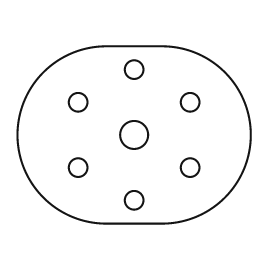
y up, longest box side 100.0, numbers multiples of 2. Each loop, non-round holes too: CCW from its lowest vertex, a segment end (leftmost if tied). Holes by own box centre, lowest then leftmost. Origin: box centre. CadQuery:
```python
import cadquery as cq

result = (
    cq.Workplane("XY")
    .moveTo(-12.0, -38.0)
    .lineTo(12.0, -38.0)
    .threePointArc((50.0, 0.0), (12.0, 38.0))
    .lineTo(-12.0, 38.0)
    .threePointArc((-50.0, 0.0), (-12.0, -38.0))
    .close()
    .moveTo(0.0, -28.0)
    .circle(4.0)
    .moveTo(-24.0, -14.0)
    .circle(4.0)
    .moveTo(24.0, -14.0)
    .circle(4.0)
    .moveTo(0.0, 0.0)
    .circle(6.0)
    .moveTo(-24.0, 14.0)
    .circle(4.0)
    .moveTo(24.0, 14.0)
    .circle(4.0)
    .moveTo(0.0, 28.0)
    .circle(4.0)
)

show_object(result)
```